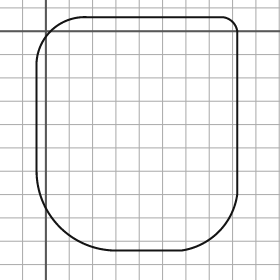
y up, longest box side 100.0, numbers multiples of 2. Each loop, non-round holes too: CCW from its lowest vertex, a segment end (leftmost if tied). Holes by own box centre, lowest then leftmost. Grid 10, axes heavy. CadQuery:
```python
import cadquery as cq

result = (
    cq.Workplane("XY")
    .moveTo(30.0, -94.0)
    .lineTo(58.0, -94.0)
    .threePointArc((74.0, -86.0), (82.0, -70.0))
    .lineTo(82.0, 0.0)
    .threePointArc((80.0, 4.0), (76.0, 6.0))
    .lineTo(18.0, 6.0)
    .threePointArc((2.0, 0.0), (-4.0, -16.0))
    .lineTo(-4.0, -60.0)
    .threePointArc((6.0, -84.0), (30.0, -94.0))
    .close()
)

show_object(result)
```